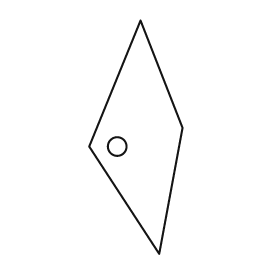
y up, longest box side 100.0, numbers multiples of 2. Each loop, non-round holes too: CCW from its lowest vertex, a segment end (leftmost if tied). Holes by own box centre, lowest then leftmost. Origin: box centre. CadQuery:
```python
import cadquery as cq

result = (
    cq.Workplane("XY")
    .moveTo(10.0, -50.0)
    .lineTo(20.0, 4.0)
    .lineTo(2.0, 50.0)
    .lineTo(-20.0, -4.0)
    .close()
    .moveTo(-8.0, -4.0)
    .circle(4.0)
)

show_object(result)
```